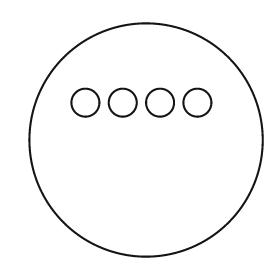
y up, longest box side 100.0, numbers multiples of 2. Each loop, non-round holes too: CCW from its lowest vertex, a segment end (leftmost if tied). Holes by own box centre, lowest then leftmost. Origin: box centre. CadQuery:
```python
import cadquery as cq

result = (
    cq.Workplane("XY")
    .moveTo(0.0, 0.0)
    .circle(50.0)
    .moveTo(-26.0, 16.0)
    .circle(6.0)
    .moveTo(-10.0, 16.0)
    .circle(6.0)
    .moveTo(6.0, 16.0)
    .circle(6.0)
    .moveTo(22.0, 16.0)
    .circle(6.0)
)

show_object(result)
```